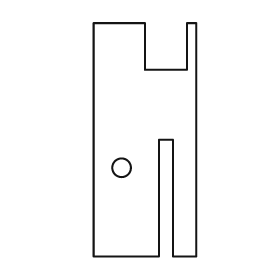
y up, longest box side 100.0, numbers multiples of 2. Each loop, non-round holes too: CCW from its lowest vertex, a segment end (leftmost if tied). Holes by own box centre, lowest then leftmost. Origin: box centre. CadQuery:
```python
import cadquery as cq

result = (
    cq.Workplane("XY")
    .moveTo(-22.0, -50.0)
    .lineTo(6.0, -50.0)
    .lineTo(6.0, 0.0)
    .lineTo(12.0, 0.0)
    .lineTo(12.0, -50.0)
    .lineTo(22.0, -50.0)
    .lineTo(22.0, 50.0)
    .lineTo(18.0, 50.0)
    .lineTo(18.0, 30.0)
    .lineTo(0.0, 30.0)
    .lineTo(0.0, 50.0)
    .lineTo(-22.0, 50.0)
    .close()
    .moveTo(-10.0, -12.0)
    .circle(4.0)
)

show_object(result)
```